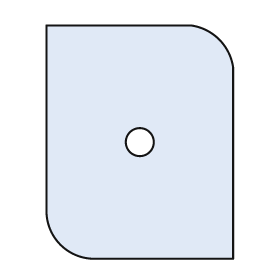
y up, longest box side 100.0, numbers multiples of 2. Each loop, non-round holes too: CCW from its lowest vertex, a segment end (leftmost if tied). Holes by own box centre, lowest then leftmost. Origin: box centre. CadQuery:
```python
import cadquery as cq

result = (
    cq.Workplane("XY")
    .moveTo(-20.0, -50.0)
    .lineTo(40.0, -50.0)
    .lineTo(40.0, 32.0)
    .threePointArc((34.0, 44.0), (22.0, 50.0))
    .lineTo(-40.0, 50.0)
    .lineTo(-40.0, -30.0)
    .threePointArc((-34.0, -44.0), (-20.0, -50.0))
    .close()
    .moveTo(0.0, 0.0)
    .circle(6.0)
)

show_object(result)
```